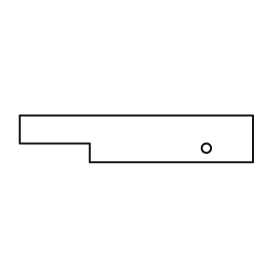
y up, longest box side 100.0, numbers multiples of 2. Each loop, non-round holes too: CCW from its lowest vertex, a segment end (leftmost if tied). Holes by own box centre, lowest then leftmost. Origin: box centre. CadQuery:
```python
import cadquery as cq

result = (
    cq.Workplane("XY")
    .moveTo(-20.0, -10.0)
    .lineTo(50.0, -10.0)
    .lineTo(50.0, 10.0)
    .lineTo(-50.0, 10.0)
    .lineTo(-50.0, -2.0)
    .lineTo(-20.0, -2.0)
    .close()
    .moveTo(30.0, -4.0)
    .circle(2.0)
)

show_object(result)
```